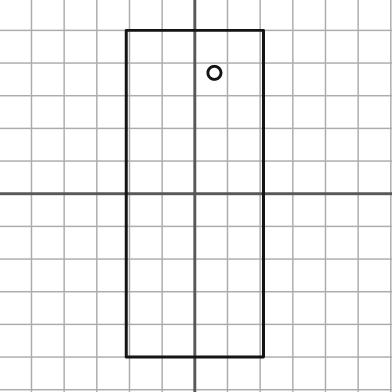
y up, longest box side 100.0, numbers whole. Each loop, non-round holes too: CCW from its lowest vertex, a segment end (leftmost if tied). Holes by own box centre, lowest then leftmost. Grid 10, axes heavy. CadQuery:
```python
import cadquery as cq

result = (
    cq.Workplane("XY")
    .moveTo(-21.0, -50.0)
    .lineTo(21.0, -50.0)
    .lineTo(21.0, 50.0)
    .lineTo(-21.0, 50.0)
    .close()
    .moveTo(6.0, 37.0)
    .circle(2.0)
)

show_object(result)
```